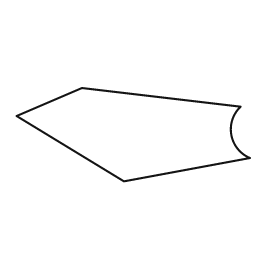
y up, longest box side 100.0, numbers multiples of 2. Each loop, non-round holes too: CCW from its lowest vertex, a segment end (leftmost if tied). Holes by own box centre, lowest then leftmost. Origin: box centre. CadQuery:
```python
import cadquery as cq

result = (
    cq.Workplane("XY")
    .moveTo(-4.0, -20.0)
    .lineTo(50.0, -10.0)
    .threePointArc((42.0, 0.0), (46.0, 12.0))
    .lineTo(-22.0, 20.0)
    .lineTo(-50.0, 8.0)
    .close()
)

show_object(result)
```